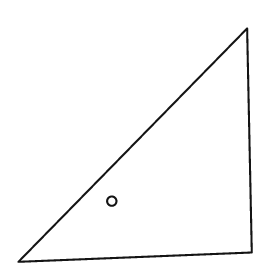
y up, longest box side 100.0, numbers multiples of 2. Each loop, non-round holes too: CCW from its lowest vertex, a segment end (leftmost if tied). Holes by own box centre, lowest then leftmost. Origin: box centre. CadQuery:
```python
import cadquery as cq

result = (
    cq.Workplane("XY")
    .moveTo(-50.0, -50.0)
    .lineTo(50.0, -46.0)
    .lineTo(48.0, 50.0)
    .close()
    .moveTo(-10.0, -24.0)
    .circle(2.0)
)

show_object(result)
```